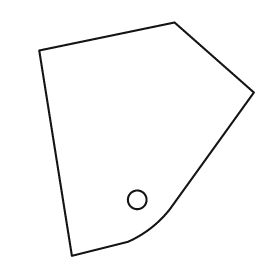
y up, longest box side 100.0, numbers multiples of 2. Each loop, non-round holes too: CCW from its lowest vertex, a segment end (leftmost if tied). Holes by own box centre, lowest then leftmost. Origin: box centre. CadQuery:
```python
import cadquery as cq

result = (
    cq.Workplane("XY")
    .moveTo(-32.0, -50.0)
    .lineTo(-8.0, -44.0)
    .threePointArc((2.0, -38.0), (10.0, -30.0))
    .lineTo(46.0, 20.0)
    .lineTo(12.0, 50.0)
    .lineTo(-46.0, 38.0)
    .close()
    .moveTo(-4.0, -26.0)
    .circle(4.0)
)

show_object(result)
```